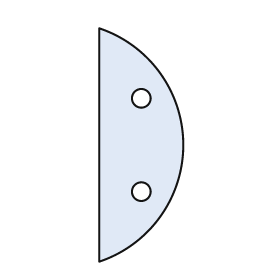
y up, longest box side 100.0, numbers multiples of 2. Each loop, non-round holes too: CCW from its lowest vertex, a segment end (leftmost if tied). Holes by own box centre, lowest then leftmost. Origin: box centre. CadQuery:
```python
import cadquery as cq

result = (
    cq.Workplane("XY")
    .moveTo(-18.0, -50.0)
    .threePointArc((18.0, 0.0), (-18.0, 50.0))
    .close()
    .moveTo(0.0, -20.0)
    .circle(4.0)
    .moveTo(0.0, 20.0)
    .circle(4.0)
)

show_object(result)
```